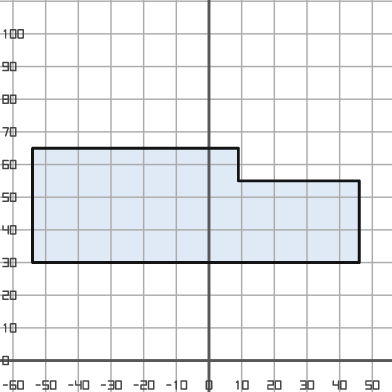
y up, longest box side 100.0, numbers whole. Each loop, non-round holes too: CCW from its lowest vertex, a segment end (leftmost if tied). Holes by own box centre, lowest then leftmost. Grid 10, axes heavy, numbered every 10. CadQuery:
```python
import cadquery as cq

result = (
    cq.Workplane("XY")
    .moveTo(-54.0, 30.0)
    .lineTo(46.0, 30.0)
    .lineTo(46.0, 55.0)
    .lineTo(9.0, 55.0)
    .lineTo(9.0, 65.0)
    .lineTo(-54.0, 65.0)
    .close()
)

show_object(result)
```